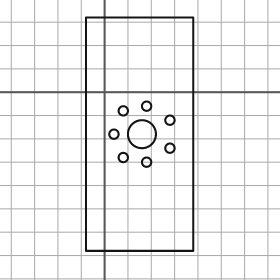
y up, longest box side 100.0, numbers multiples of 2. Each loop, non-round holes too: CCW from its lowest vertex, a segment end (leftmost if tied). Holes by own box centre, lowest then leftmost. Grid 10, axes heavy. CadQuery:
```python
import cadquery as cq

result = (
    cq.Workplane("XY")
    .moveTo(-8.0, -68.0)
    .lineTo(38.0, -68.0)
    .lineTo(38.0, 32.0)
    .lineTo(-8.0, 32.0)
    .close()
    .moveTo(18.0, -30.0)
    .circle(2.0)
    .moveTo(8.0, -28.0)
    .circle(2.0)
    .moveTo(28.0, -24.0)
    .circle(2.0)
    .moveTo(4.0, -18.0)
    .circle(2.0)
    .moveTo(16.0, -18.0)
    .circle(6.0)
    .moveTo(28.0, -12.0)
    .circle(2.0)
    .moveTo(8.0, -8.0)
    .circle(2.0)
    .moveTo(18.0, -6.0)
    .circle(2.0)
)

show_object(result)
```